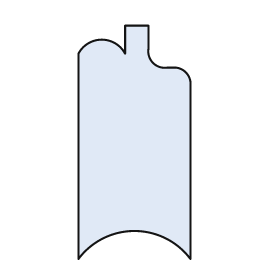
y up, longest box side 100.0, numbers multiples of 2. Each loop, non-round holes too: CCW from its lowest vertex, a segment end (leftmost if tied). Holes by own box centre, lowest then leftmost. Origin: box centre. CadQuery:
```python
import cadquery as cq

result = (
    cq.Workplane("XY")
    .moveTo(-24.0, -50.0)
    .threePointArc((0.0, -38.0), (24.0, -50.0))
    .lineTo(24.0, 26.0)
    .threePointArc((22.0, 30.0), (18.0, 32.0))
    .lineTo(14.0, 32.0)
    .threePointArc((8.0, 34.0), (6.0, 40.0))
    .lineTo(6.0, 50.0)
    .lineTo(-4.0, 50.0)
    .lineTo(-4.0, 38.0)
    .threePointArc((-14.0, 44.0), (-24.0, 38.0))
    .close()
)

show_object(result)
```